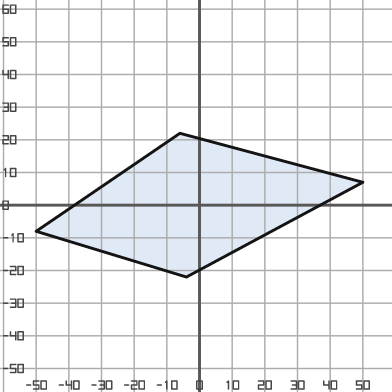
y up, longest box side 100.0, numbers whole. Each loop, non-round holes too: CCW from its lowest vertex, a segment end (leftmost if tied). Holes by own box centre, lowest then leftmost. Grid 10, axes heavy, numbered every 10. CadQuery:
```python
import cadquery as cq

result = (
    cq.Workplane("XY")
    .moveTo(-4.0, -22.0)
    .lineTo(50.0, 7.0)
    .lineTo(-6.0, 22.0)
    .lineTo(-50.0, -8.0)
    .close()
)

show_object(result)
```